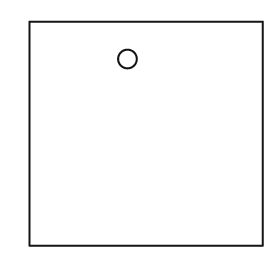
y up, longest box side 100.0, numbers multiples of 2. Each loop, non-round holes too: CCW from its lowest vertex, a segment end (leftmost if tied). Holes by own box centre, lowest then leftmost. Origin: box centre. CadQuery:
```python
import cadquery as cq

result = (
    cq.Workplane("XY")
    .moveTo(-50.0, -48.0)
    .lineTo(50.0, -48.0)
    .lineTo(50.0, 48.0)
    .lineTo(-50.0, 48.0)
    .close()
    .moveTo(-8.0, 32.0)
    .circle(4.0)
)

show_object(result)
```